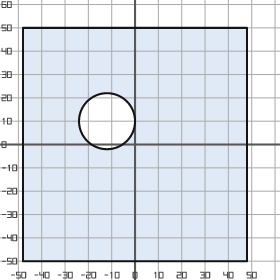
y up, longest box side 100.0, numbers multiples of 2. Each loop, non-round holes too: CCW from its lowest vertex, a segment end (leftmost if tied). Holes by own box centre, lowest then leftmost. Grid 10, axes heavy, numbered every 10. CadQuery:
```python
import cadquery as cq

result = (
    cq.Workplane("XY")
    .moveTo(-48.0, -50.0)
    .lineTo(48.0, -50.0)
    .lineTo(48.0, 50.0)
    .lineTo(-48.0, 50.0)
    .close()
    .moveTo(-12.0, 10.0)
    .circle(12.0)
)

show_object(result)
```